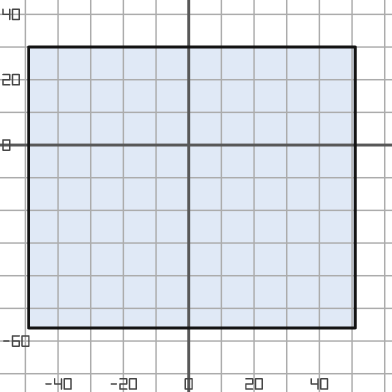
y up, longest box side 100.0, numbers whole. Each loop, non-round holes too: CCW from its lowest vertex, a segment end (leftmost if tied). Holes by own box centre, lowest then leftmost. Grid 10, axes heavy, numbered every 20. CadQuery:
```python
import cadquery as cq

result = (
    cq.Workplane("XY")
    .moveTo(-49.0, -56.0)
    .lineTo(51.0, -56.0)
    .lineTo(51.0, 30.0)
    .lineTo(-49.0, 30.0)
    .close()
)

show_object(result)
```